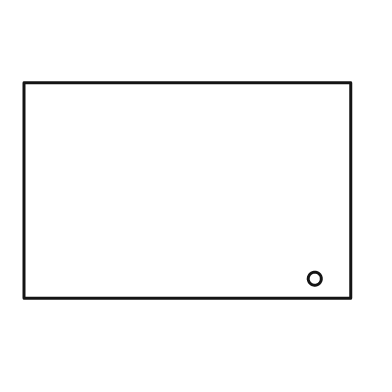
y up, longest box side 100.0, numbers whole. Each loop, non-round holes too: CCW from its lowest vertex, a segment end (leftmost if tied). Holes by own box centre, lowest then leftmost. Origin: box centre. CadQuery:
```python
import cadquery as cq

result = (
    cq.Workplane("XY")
    .moveTo(-50.0, -33.0)
    .lineTo(50.0, -33.0)
    .lineTo(50.0, 33.0)
    .lineTo(-50.0, 33.0)
    .close()
    .moveTo(39.0, -27.0)
    .circle(2.0)
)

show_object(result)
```